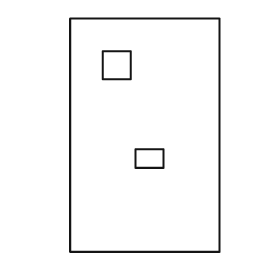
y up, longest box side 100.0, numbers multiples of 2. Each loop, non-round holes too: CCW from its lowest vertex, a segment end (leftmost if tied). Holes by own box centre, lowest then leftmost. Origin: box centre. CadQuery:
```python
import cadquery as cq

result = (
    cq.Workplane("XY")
    .moveTo(-32.0, -50.0)
    .lineTo(32.0, -50.0)
    .lineTo(32.0, 50.0)
    .lineTo(-32.0, 50.0)
    .close()
    .moveTo(-4.0, -14.0)
    .lineTo(8.0, -14.0)
    .lineTo(8.0, -6.0)
    .lineTo(-4.0, -6.0)
    .close()
    .moveTo(-18.0, 24.0)
    .lineTo(-6.0, 24.0)
    .lineTo(-6.0, 36.0)
    .lineTo(-18.0, 36.0)
    .close()
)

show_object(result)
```